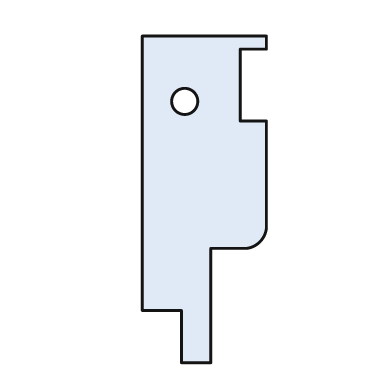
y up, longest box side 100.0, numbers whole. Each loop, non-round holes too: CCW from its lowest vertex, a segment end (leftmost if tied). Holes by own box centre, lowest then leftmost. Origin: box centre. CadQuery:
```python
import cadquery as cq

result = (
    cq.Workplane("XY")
    .moveTo(-7.0, -50.0)
    .lineTo(2.0, -50.0)
    .lineTo(2.0, -15.0)
    .lineTo(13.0, -15.0)
    .threePointArc((17.0, -13.0), (19.0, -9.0))
    .lineTo(19.0, 24.0)
    .lineTo(11.0, 24.0)
    .lineTo(11.0, 46.0)
    .lineTo(19.0, 46.0)
    .lineTo(19.0, 50.0)
    .lineTo(-19.0, 50.0)
    .lineTo(-19.0, -34.0)
    .lineTo(-7.0, -34.0)
    .close()
    .moveTo(-6.0, 30.0)
    .circle(4.0)
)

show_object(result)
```